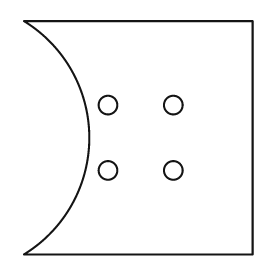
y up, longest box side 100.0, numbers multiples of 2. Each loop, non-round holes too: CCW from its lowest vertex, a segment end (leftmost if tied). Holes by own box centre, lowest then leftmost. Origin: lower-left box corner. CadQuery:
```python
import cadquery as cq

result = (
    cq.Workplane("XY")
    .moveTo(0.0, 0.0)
    .lineTo(98.0, 0.0)
    .lineTo(98.0, 100.0)
    .lineTo(0.0, 100.0)
    .threePointArc((28.0, 50.0), (0.0, 0.0))
    .close()
    .moveTo(36.0, 36.0)
    .circle(4.0)
    .moveTo(64.0, 36.0)
    .circle(4.0)
    .moveTo(36.0, 64.0)
    .circle(4.0)
    .moveTo(64.0, 64.0)
    .circle(4.0)
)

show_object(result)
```